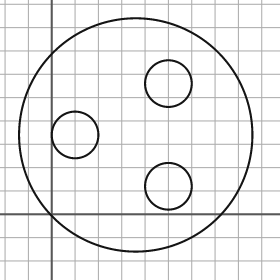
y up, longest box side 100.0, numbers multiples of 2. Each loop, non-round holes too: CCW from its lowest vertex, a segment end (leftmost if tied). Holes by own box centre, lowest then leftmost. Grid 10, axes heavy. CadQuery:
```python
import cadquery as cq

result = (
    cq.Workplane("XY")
    .moveTo(36.0, 34.0)
    .circle(50.0)
    .moveTo(50.0, 12.0)
    .circle(10.0)
    .moveTo(10.0, 34.0)
    .circle(10.0)
    .moveTo(50.0, 56.0)
    .circle(10.0)
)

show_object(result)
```